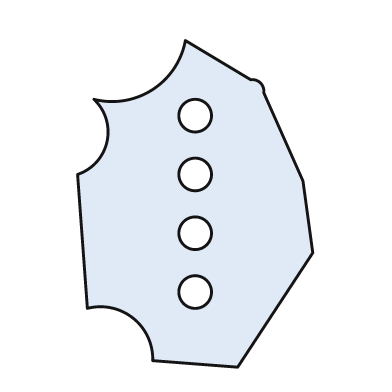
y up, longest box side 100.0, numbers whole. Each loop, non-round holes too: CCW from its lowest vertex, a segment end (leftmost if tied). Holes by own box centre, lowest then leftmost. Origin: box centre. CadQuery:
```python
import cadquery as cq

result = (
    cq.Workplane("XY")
    .moveTo(13.0, -50.0)
    .lineTo(36.0, -15.0)
    .lineTo(33.0, 7.0)
    .lineTo(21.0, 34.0)
    .threePointArc((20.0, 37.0), (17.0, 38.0))
    .lineTo(-3.0, 50.0)
    .threePointArc((-13.0, 35.0), (-31.0, 32.0))
    .threePointArc((-27.0, 19.0), (-36.0, 9.0))
    .lineTo(-33.0, -32.0)
    .threePointArc((-19.0, -35.0), (-13.0, -48.0))
    .close()
    .moveTo(0.0, -27.0)
    .circle(5.0)
    .moveTo(0.0, -9.0)
    .circle(5.0)
    .moveTo(0.0, 9.0)
    .circle(5.0)
    .moveTo(0.0, 27.0)
    .circle(5.0)
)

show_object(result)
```